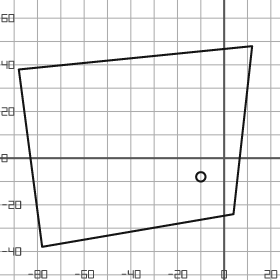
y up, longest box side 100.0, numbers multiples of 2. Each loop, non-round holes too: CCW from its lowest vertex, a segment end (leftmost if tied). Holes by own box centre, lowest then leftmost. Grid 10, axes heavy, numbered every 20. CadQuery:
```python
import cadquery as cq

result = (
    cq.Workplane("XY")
    .moveTo(-78.0, -38.0)
    .lineTo(4.0, -24.0)
    .lineTo(12.0, 48.0)
    .lineTo(-88.0, 38.0)
    .close()
    .moveTo(-10.0, -8.0)
    .circle(2.0)
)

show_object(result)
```